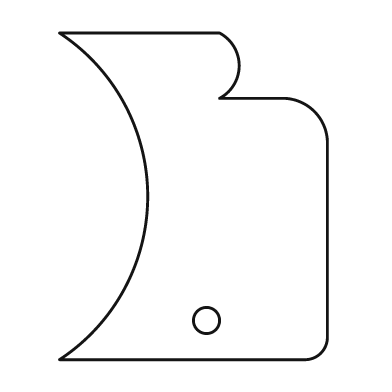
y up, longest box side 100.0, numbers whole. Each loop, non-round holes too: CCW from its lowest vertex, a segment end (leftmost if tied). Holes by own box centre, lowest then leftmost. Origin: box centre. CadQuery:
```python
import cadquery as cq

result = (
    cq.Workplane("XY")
    .moveTo(-41.0, -50.0)
    .lineTo(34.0, -50.0)
    .threePointArc((39.0, -48.0), (41.0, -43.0))
    .lineTo(41.0, 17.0)
    .threePointArc((37.0, 26.0), (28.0, 30.0))
    .lineTo(8.0, 30.0)
    .threePointArc((14.0, 40.0), (8.0, 50.0))
    .lineTo(-41.0, 50.0)
    .threePointArc((-14.0, 0.0), (-41.0, -50.0))
    .close()
    .moveTo(4.0, -38.0)
    .circle(4.0)
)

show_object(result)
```